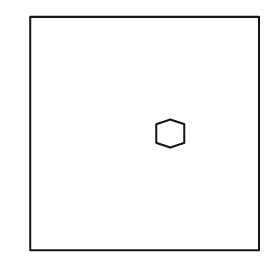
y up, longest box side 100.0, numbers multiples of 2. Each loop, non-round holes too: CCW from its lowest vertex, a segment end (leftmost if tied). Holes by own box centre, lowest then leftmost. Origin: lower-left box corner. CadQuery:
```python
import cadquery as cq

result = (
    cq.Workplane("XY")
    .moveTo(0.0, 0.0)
    .lineTo(98.0, 0.0)
    .lineTo(98.0, 100.0)
    .lineTo(0.0, 100.0)
    .close()
    .moveTo(60.0, 44.0)
    .lineTo(66.0, 46.0)
    .lineTo(66.0, 54.0)
    .lineTo(60.0, 56.0)
    .lineTo(54.0, 54.0)
    .lineTo(54.0, 46.0)
    .close()
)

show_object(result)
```